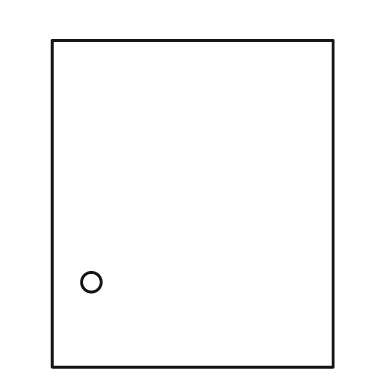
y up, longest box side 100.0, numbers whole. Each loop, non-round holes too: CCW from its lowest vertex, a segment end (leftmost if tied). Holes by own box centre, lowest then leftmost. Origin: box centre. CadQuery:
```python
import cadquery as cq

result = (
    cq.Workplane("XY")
    .moveTo(-43.0, -50.0)
    .lineTo(43.0, -50.0)
    .lineTo(43.0, 50.0)
    .lineTo(-43.0, 50.0)
    .close()
    .moveTo(-31.0, -24.0)
    .circle(3.0)
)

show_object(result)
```